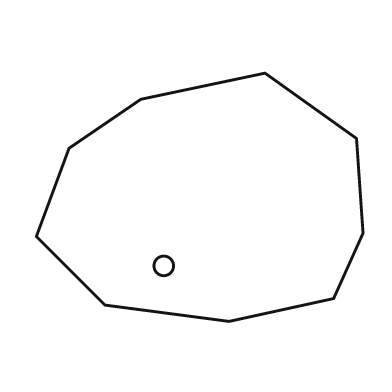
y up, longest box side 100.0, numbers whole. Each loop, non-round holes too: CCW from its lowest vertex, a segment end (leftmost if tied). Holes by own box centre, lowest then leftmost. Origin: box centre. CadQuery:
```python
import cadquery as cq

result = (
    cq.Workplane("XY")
    .moveTo(9.0, -38.0)
    .lineTo(41.0, -31.0)
    .lineTo(50.0, -11.0)
    .lineTo(48.0, 18.0)
    .lineTo(20.0, 38.0)
    .lineTo(-18.0, 30.0)
    .lineTo(-40.0, 15.0)
    .lineTo(-50.0, -12.0)
    .lineTo(-29.0, -33.0)
    .close()
    .moveTo(-11.0, -21.0)
    .circle(3.0)
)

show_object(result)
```